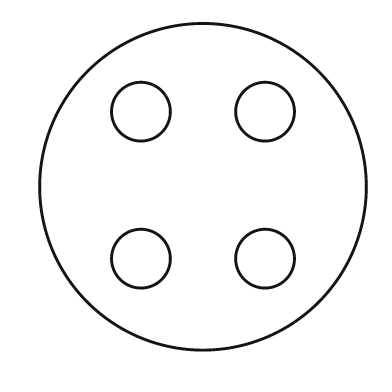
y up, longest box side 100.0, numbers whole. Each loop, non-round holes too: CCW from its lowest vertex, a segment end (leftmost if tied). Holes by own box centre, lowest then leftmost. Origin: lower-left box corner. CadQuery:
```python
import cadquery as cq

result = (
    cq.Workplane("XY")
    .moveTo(50.0, 50.0)
    .circle(50.0)
    .moveTo(31.0, 28.0)
    .circle(9.0)
    .moveTo(69.0, 28.0)
    .circle(9.0)
    .moveTo(31.0, 73.0)
    .circle(9.0)
    .moveTo(69.0, 73.0)
    .circle(9.0)
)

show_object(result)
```